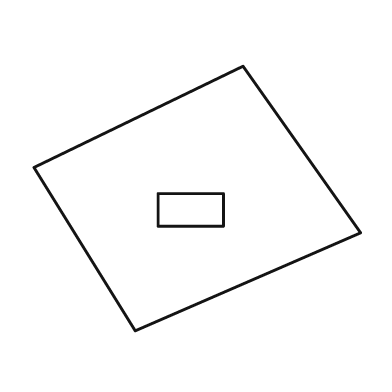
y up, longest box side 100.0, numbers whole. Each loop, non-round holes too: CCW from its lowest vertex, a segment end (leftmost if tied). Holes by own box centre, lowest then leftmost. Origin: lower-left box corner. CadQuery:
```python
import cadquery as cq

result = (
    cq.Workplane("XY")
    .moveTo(31.0, 0.0)
    .lineTo(100.0, 30.0)
    .lineTo(64.0, 81.0)
    .lineTo(0.0, 50.0)
    .close()
    .moveTo(38.0, 32.0)
    .lineTo(58.0, 32.0)
    .lineTo(58.0, 42.0)
    .lineTo(38.0, 42.0)
    .close()
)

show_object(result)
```